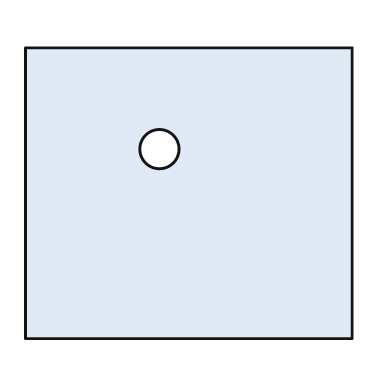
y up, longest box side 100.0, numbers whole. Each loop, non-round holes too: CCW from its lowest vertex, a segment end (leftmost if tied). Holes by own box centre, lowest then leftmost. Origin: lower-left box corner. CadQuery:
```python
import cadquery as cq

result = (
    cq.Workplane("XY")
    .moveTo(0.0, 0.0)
    .lineTo(100.0, 0.0)
    .lineTo(100.0, 89.0)
    .lineTo(0.0, 89.0)
    .close()
    .moveTo(41.0, 58.0)
    .circle(6.0)
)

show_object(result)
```